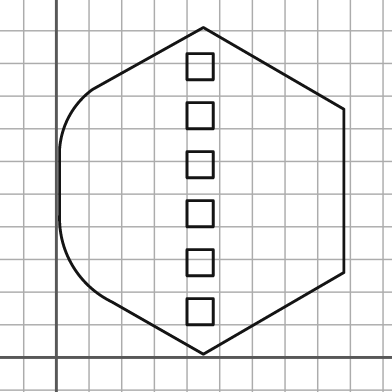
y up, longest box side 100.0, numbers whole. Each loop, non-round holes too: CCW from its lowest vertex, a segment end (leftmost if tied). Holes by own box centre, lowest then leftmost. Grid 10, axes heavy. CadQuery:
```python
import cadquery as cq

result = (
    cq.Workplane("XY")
    .moveTo(45.0, 1.0)
    .lineTo(88.0, 26.0)
    .lineTo(88.0, 76.0)
    .lineTo(45.0, 101.0)
    .lineTo(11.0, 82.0)
    .threePointArc((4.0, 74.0), (1.0, 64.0))
    .lineTo(1.0, 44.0)
    .threePointArc((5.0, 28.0), (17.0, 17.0))
    .close()
    .moveTo(40.0, 10.0)
    .lineTo(48.0, 10.0)
    .lineTo(48.0, 18.0)
    .lineTo(40.0, 18.0)
    .close()
    .moveTo(40.0, 25.0)
    .lineTo(48.0, 25.0)
    .lineTo(48.0, 33.0)
    .lineTo(40.0, 33.0)
    .close()
    .moveTo(40.0, 40.0)
    .lineTo(48.0, 40.0)
    .lineTo(48.0, 48.0)
    .lineTo(40.0, 48.0)
    .close()
    .moveTo(40.0, 55.0)
    .lineTo(48.0, 55.0)
    .lineTo(48.0, 63.0)
    .lineTo(40.0, 63.0)
    .close()
    .moveTo(40.0, 70.0)
    .lineTo(48.0, 70.0)
    .lineTo(48.0, 78.0)
    .lineTo(40.0, 78.0)
    .close()
    .moveTo(40.0, 85.0)
    .lineTo(48.0, 85.0)
    .lineTo(48.0, 93.0)
    .lineTo(40.0, 93.0)
    .close()
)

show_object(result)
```